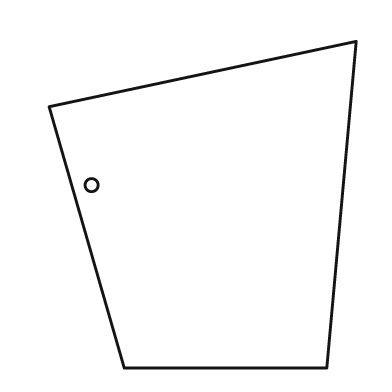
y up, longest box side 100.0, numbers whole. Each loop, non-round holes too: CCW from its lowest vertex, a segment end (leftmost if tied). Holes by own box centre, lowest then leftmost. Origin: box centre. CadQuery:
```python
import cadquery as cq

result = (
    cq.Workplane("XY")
    .moveTo(-24.0, -50.0)
    .lineTo(38.0, -50.0)
    .lineTo(47.0, 50.0)
    .lineTo(-47.0, 30.0)
    .close()
    .moveTo(-34.0, 6.0)
    .circle(2.0)
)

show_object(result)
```